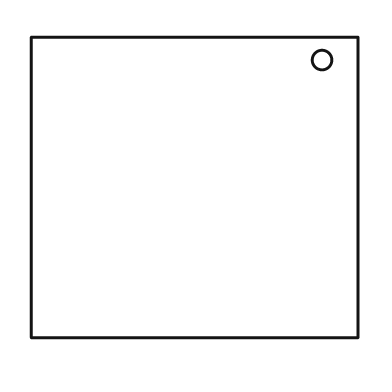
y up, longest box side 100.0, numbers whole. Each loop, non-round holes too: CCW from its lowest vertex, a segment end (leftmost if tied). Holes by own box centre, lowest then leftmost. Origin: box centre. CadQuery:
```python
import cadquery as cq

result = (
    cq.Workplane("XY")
    .moveTo(-50.0, -46.0)
    .lineTo(50.0, -46.0)
    .lineTo(50.0, 46.0)
    .lineTo(-50.0, 46.0)
    .close()
    .moveTo(39.0, 39.0)
    .circle(3.0)
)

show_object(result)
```